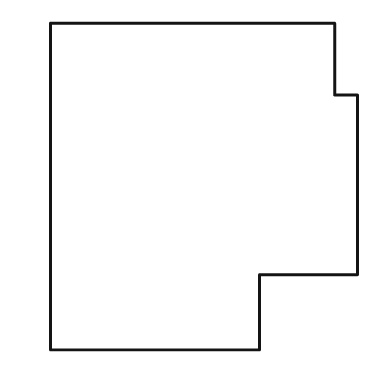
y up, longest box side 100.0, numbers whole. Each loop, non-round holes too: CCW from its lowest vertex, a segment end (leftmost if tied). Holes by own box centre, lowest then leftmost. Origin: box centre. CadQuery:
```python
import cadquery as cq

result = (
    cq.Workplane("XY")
    .moveTo(-47.0, -50.0)
    .lineTo(17.0, -50.0)
    .lineTo(17.0, -27.0)
    .lineTo(47.0, -27.0)
    .lineTo(47.0, 28.0)
    .lineTo(40.0, 28.0)
    .lineTo(40.0, 50.0)
    .lineTo(-47.0, 50.0)
    .close()
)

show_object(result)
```